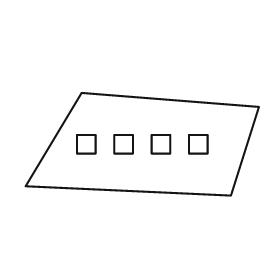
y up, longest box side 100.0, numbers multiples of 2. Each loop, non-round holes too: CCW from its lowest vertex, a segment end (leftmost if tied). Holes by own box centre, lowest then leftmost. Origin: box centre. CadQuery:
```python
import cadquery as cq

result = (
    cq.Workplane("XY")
    .moveTo(38.0, -22.0)
    .lineTo(50.0, 16.0)
    .lineTo(-26.0, 22.0)
    .lineTo(-50.0, -18.0)
    .close()
    .moveTo(-28.0, -4.0)
    .lineTo(-20.0, -4.0)
    .lineTo(-20.0, 4.0)
    .lineTo(-28.0, 4.0)
    .close()
    .moveTo(-12.0, -4.0)
    .lineTo(-4.0, -4.0)
    .lineTo(-4.0, 4.0)
    .lineTo(-12.0, 4.0)
    .close()
    .moveTo(4.0, -4.0)
    .lineTo(12.0, -4.0)
    .lineTo(12.0, 4.0)
    .lineTo(4.0, 4.0)
    .close()
    .moveTo(20.0, -4.0)
    .lineTo(28.0, -4.0)
    .lineTo(28.0, 4.0)
    .lineTo(20.0, 4.0)
    .close()
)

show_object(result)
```